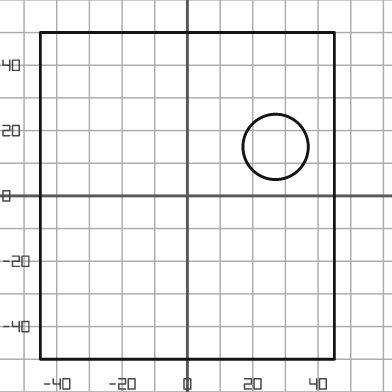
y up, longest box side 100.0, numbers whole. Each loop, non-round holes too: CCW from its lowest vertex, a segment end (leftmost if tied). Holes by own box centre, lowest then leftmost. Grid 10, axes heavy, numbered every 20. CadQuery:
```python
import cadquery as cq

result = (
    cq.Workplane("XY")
    .moveTo(-45.0, -50.0)
    .lineTo(45.0, -50.0)
    .lineTo(45.0, 50.0)
    .lineTo(-45.0, 50.0)
    .close()
    .moveTo(27.0, 15.0)
    .circle(10.0)
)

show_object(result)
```